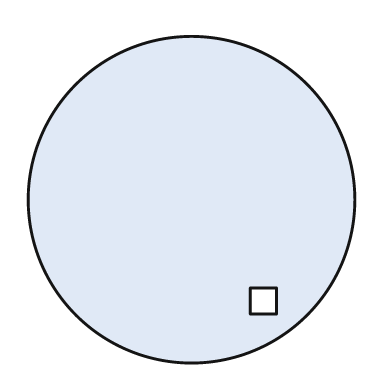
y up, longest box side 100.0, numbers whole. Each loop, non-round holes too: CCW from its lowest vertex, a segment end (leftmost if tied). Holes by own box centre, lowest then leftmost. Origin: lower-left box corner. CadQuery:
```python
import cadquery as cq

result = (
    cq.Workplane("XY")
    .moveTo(50.0, 50.0)
    .circle(50.0)
    .moveTo(68.0, 15.0)
    .lineTo(76.0, 15.0)
    .lineTo(76.0, 23.0)
    .lineTo(68.0, 23.0)
    .close()
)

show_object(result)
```